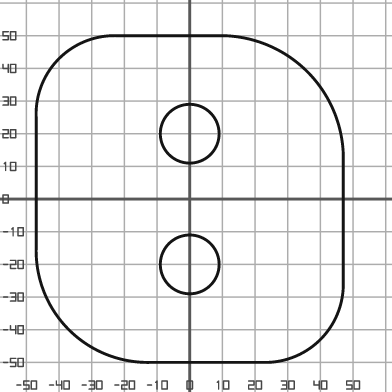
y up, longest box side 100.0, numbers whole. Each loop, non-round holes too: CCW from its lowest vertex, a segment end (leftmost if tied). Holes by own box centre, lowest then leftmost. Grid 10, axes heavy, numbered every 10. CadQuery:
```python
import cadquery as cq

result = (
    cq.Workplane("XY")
    .moveTo(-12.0, -50.0)
    .lineTo(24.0, -50.0)
    .threePointArc((40.0, -43.0), (47.0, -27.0))
    .lineTo(47.0, 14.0)
    .threePointArc((36.0, 39.0), (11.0, 50.0))
    .lineTo(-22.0, 50.0)
    .threePointArc((-40.0, 43.0), (-47.0, 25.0))
    .lineTo(-47.0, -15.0)
    .threePointArc((-37.0, -40.0), (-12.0, -50.0))
    .close()
    .moveTo(0.0, -20.0)
    .circle(9.0)
    .moveTo(0.0, 20.0)
    .circle(9.0)
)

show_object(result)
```